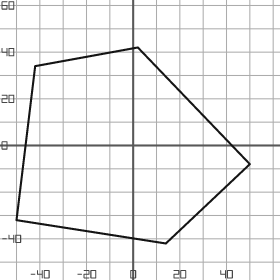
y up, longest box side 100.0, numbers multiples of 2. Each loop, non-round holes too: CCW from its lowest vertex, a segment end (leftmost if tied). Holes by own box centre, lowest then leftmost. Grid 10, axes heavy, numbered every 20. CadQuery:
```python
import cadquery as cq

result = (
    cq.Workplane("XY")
    .moveTo(14.0, -42.0)
    .lineTo(50.0, -8.0)
    .lineTo(2.0, 42.0)
    .lineTo(-42.0, 34.0)
    .lineTo(-50.0, -32.0)
    .close()
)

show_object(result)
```